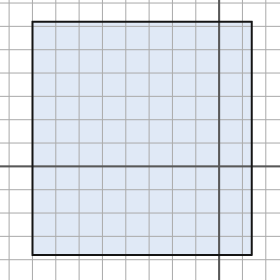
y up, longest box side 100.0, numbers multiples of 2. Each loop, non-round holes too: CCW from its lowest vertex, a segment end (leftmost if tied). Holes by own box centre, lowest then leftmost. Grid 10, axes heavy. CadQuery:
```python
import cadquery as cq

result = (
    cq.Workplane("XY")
    .moveTo(-80.0, -38.0)
    .lineTo(14.0, -38.0)
    .lineTo(14.0, 62.0)
    .lineTo(-80.0, 62.0)
    .close()
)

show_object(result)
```